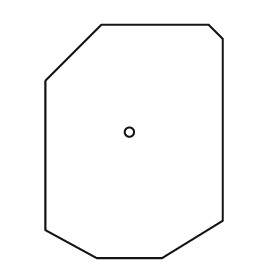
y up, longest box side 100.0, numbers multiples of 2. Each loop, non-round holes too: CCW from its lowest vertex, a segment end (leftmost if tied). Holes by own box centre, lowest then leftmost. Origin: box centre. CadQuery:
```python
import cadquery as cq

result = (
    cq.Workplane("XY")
    .moveTo(-16.0, -50.0)
    .lineTo(12.0, -50.0)
    .lineTo(38.0, -34.0)
    .lineTo(38.0, 44.0)
    .lineTo(32.0, 50.0)
    .lineTo(-14.0, 50.0)
    .lineTo(-38.0, 26.0)
    .lineTo(-38.0, -38.0)
    .close()
    .moveTo(-2.0, 4.0)
    .circle(2.0)
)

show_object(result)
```